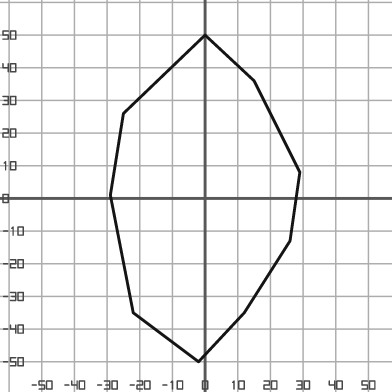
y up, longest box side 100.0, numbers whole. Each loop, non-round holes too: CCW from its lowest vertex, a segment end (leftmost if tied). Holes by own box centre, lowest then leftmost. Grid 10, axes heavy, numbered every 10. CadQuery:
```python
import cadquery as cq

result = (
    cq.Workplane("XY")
    .moveTo(-2.0, -50.0)
    .lineTo(12.0, -35.0)
    .lineTo(26.0, -13.0)
    .lineTo(29.0, 8.0)
    .lineTo(15.0, 36.0)
    .lineTo(0.0, 50.0)
    .lineTo(-25.0, 26.0)
    .lineTo(-29.0, 1.0)
    .lineTo(-22.0, -35.0)
    .close()
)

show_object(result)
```